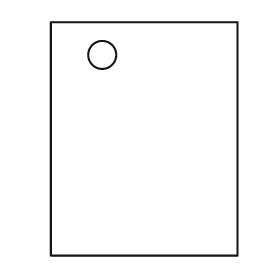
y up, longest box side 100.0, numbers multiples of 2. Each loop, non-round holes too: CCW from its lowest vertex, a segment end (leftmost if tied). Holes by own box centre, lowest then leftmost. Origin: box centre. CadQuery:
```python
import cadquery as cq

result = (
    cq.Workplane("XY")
    .moveTo(-40.0, -50.0)
    .lineTo(40.0, -50.0)
    .lineTo(40.0, 50.0)
    .lineTo(-40.0, 50.0)
    .close()
    .moveTo(-18.0, 36.0)
    .circle(6.0)
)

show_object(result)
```